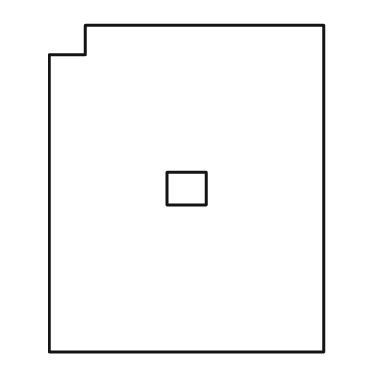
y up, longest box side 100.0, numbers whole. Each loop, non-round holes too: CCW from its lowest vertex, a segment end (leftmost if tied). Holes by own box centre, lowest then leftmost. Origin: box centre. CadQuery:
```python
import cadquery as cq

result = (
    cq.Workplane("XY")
    .moveTo(-42.0, -50.0)
    .lineTo(42.0, -50.0)
    .lineTo(42.0, 50.0)
    .lineTo(-31.0, 50.0)
    .lineTo(-31.0, 41.0)
    .lineTo(-42.0, 41.0)
    .close()
    .moveTo(-6.0, -5.0)
    .lineTo(6.0, -5.0)
    .lineTo(6.0, 5.0)
    .lineTo(-6.0, 5.0)
    .close()
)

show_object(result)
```